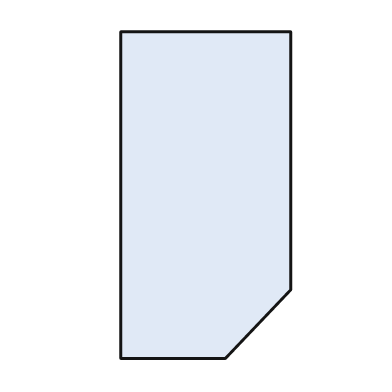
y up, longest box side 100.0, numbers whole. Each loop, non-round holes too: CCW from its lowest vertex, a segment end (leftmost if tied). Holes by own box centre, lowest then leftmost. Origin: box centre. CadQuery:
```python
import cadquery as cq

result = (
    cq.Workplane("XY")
    .moveTo(-26.0, -50.0)
    .lineTo(6.0, -50.0)
    .lineTo(26.0, -29.0)
    .lineTo(26.0, 50.0)
    .lineTo(-26.0, 50.0)
    .close()
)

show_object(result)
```